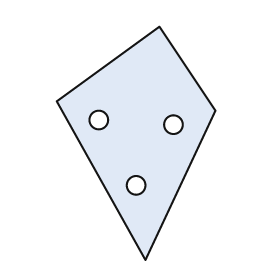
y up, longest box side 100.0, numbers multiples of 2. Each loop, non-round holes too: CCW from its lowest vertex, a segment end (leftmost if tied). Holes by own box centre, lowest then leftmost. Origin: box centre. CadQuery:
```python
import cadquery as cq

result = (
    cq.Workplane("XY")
    .moveTo(4.0, -50.0)
    .lineTo(34.0, 14.0)
    .lineTo(10.0, 50.0)
    .lineTo(-34.0, 18.0)
    .close()
    .moveTo(0.0, -18.0)
    .circle(4.0)
    .moveTo(16.0, 8.0)
    .circle(4.0)
    .moveTo(-16.0, 10.0)
    .circle(4.0)
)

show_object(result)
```